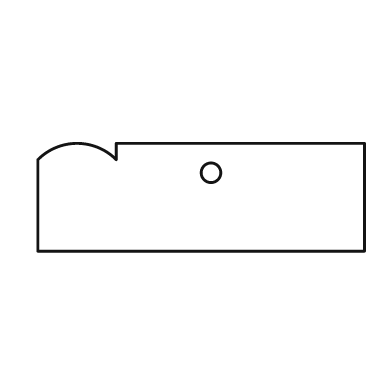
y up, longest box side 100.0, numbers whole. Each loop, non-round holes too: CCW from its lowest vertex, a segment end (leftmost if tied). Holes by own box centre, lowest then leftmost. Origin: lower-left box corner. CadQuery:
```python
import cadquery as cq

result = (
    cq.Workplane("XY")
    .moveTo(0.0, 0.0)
    .lineTo(100.0, 0.0)
    .lineTo(100.0, 33.0)
    .lineTo(24.0, 33.0)
    .lineTo(24.0, 28.0)
    .threePointArc((12.0, 33.0), (0.0, 28.0))
    .close()
    .moveTo(53.0, 24.0)
    .circle(3.0)
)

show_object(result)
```